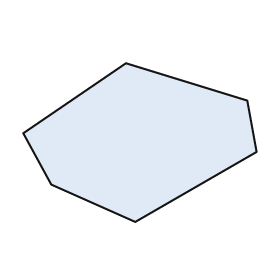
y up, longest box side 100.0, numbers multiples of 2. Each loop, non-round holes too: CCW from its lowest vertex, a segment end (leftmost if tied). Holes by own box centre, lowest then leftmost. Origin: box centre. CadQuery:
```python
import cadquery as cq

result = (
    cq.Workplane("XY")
    .moveTo(-2.0, -34.0)
    .lineTo(50.0, -4.0)
    .lineTo(46.0, 18.0)
    .lineTo(-6.0, 34.0)
    .lineTo(-50.0, 4.0)
    .lineTo(-38.0, -18.0)
    .close()
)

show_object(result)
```